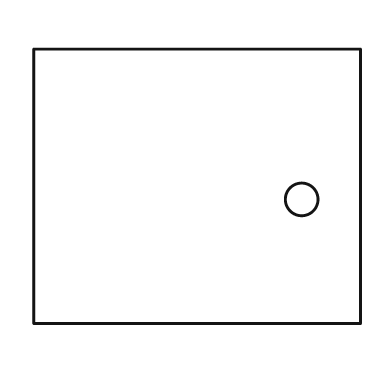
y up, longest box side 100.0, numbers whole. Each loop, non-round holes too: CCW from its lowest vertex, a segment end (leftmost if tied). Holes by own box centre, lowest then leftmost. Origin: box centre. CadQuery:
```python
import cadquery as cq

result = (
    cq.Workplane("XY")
    .moveTo(-50.0, -42.0)
    .lineTo(50.0, -42.0)
    .lineTo(50.0, 42.0)
    .lineTo(-50.0, 42.0)
    .close()
    .moveTo(32.0, -4.0)
    .circle(5.0)
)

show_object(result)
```